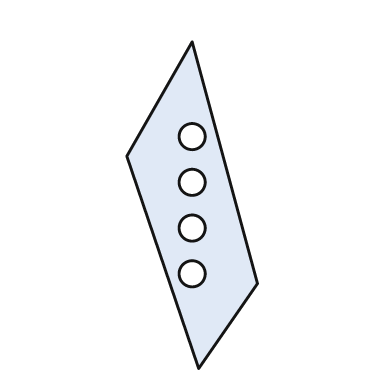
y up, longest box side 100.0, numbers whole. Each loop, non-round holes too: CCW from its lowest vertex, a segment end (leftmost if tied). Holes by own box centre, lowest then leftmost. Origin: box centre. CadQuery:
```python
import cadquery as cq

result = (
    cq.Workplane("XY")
    .moveTo(2.0, -50.0)
    .lineTo(20.0, -24.0)
    .lineTo(0.0, 50.0)
    .lineTo(-20.0, 15.0)
    .close()
    .moveTo(0.0, -21.0)
    .circle(4.0)
    .moveTo(0.0, -7.0)
    .circle(4.0)
    .moveTo(0.0, 7.0)
    .circle(4.0)
    .moveTo(0.0, 21.0)
    .circle(4.0)
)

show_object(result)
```